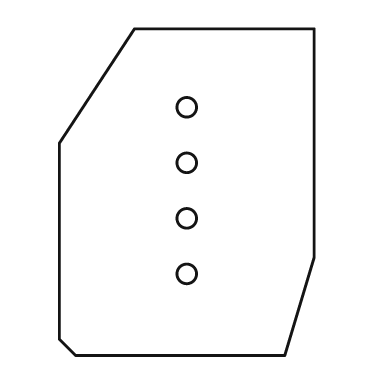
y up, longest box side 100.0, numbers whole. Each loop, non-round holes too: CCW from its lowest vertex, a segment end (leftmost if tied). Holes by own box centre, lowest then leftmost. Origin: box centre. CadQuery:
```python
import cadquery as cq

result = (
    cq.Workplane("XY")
    .moveTo(-34.0, -50.0)
    .lineTo(30.0, -50.0)
    .lineTo(39.0, -20.0)
    .lineTo(39.0, 50.0)
    .lineTo(-16.0, 50.0)
    .lineTo(-39.0, 15.0)
    .lineTo(-39.0, -45.0)
    .close()
    .moveTo(0.0, -25.0)
    .circle(3.0)
    .moveTo(0.0, -8.0)
    .circle(3.0)
    .moveTo(0.0, 9.0)
    .circle(3.0)
    .moveTo(0.0, 26.0)
    .circle(3.0)
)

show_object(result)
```